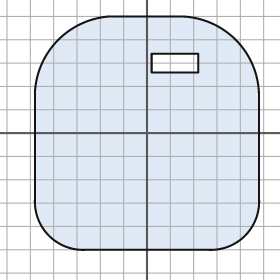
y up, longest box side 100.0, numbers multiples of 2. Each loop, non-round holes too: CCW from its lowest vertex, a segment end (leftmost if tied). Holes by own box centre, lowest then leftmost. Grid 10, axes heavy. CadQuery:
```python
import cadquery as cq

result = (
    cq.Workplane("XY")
    .moveTo(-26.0, -50.0)
    .lineTo(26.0, -50.0)
    .threePointArc((42.0, -44.0), (48.0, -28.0))
    .lineTo(48.0, 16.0)
    .threePointArc((38.0, 40.0), (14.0, 50.0))
    .lineTo(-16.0, 50.0)
    .threePointArc((-38.0, 40.0), (-48.0, 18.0))
    .lineTo(-48.0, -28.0)
    .threePointArc((-42.0, -44.0), (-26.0, -50.0))
    .close()
    .moveTo(2.0, 26.0)
    .lineTo(22.0, 26.0)
    .lineTo(22.0, 34.0)
    .lineTo(2.0, 34.0)
    .close()
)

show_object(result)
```